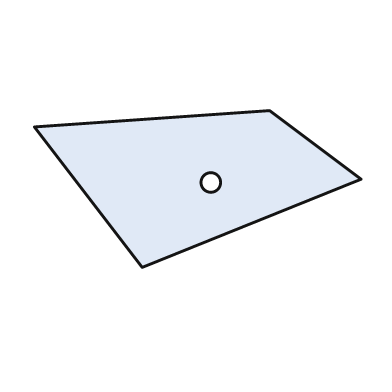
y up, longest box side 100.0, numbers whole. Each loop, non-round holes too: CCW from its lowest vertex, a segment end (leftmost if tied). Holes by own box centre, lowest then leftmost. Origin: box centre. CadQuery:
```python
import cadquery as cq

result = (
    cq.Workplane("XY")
    .moveTo(-17.0, -24.0)
    .lineTo(50.0, 3.0)
    .lineTo(22.0, 24.0)
    .lineTo(-50.0, 19.0)
    .close()
    .moveTo(4.0, 2.0)
    .circle(3.0)
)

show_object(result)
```